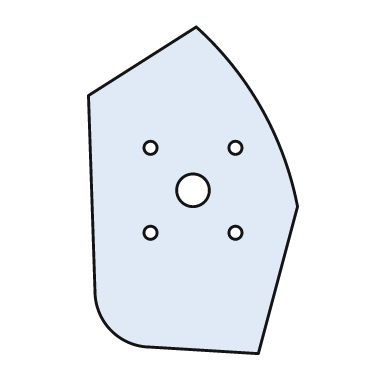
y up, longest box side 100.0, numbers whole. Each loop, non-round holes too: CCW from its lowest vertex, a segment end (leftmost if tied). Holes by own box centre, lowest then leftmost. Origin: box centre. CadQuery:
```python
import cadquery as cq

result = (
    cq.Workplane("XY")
    .moveTo(20.0, -50.0)
    .lineTo(32.0, -5.0)
    .threePointArc((21.0, 25.0), (1.0, 50.0))
    .lineTo(-32.0, 29.0)
    .lineTo(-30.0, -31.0)
    .threePointArc((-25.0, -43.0), (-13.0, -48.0))
    .close()
    .moveTo(-13.0, -13.0)
    .circle(2.0)
    .moveTo(13.0, -13.0)
    .circle(2.0)
    .moveTo(0.0, 0.0)
    .circle(5.0)
    .moveTo(-13.0, 13.0)
    .circle(2.0)
    .moveTo(13.0, 13.0)
    .circle(2.0)
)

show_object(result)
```